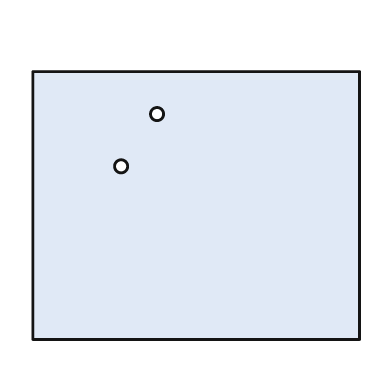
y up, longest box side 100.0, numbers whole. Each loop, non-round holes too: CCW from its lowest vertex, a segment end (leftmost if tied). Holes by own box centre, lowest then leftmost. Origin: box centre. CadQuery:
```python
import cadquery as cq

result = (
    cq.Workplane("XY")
    .moveTo(-50.0, -41.0)
    .lineTo(50.0, -41.0)
    .lineTo(50.0, 41.0)
    .lineTo(-50.0, 41.0)
    .close()
    .moveTo(-23.0, 12.0)
    .circle(2.0)
    .moveTo(-12.0, 28.0)
    .circle(2.0)
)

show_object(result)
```